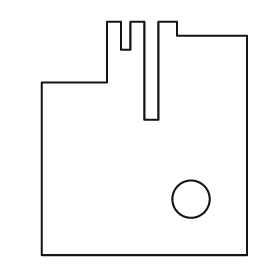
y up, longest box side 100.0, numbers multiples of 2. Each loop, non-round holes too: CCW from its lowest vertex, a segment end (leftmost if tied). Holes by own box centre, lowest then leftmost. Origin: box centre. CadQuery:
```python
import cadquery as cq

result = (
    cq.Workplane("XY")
    .moveTo(-44.0, -50.0)
    .lineTo(44.0, -50.0)
    .lineTo(44.0, 44.0)
    .lineTo(14.0, 44.0)
    .lineTo(14.0, 50.0)
    .lineTo(6.0, 50.0)
    .lineTo(6.0, 8.0)
    .lineTo(0.0, 8.0)
    .lineTo(0.0, 50.0)
    .lineTo(-6.0, 50.0)
    .lineTo(-6.0, 38.0)
    .lineTo(-10.0, 38.0)
    .lineTo(-10.0, 50.0)
    .lineTo(-16.0, 50.0)
    .lineTo(-16.0, 24.0)
    .lineTo(-44.0, 24.0)
    .close()
    .moveTo(20.0, -26.0)
    .circle(8.0)
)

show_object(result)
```